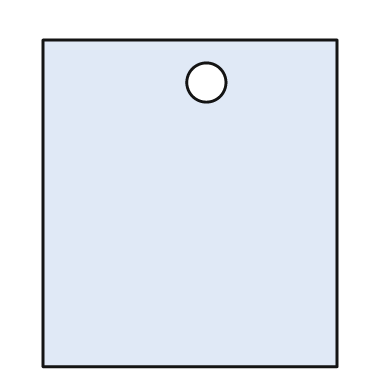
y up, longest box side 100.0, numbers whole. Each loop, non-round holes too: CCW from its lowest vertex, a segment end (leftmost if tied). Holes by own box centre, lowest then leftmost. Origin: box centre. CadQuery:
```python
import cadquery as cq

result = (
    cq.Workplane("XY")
    .moveTo(-45.0, -50.0)
    .lineTo(45.0, -50.0)
    .lineTo(45.0, 50.0)
    .lineTo(-45.0, 50.0)
    .close()
    .moveTo(5.0, 37.0)
    .circle(6.0)
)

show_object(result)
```